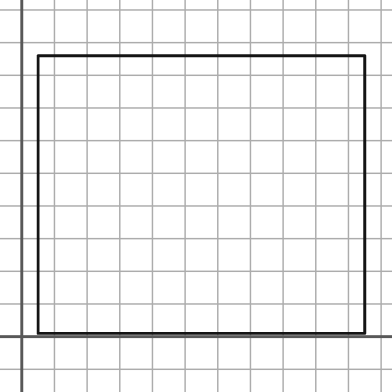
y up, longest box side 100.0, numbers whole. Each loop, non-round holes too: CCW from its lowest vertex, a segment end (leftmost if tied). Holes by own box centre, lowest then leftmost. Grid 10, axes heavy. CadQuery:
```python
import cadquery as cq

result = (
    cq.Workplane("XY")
    .moveTo(5.0, 1.0)
    .lineTo(105.0, 1.0)
    .lineTo(105.0, 86.0)
    .lineTo(5.0, 86.0)
    .close()
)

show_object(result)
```